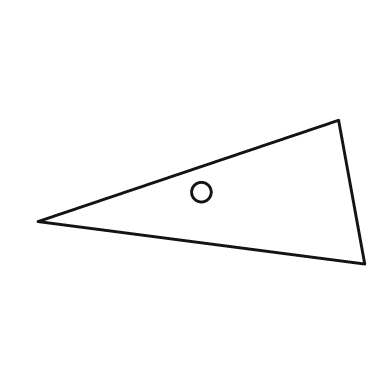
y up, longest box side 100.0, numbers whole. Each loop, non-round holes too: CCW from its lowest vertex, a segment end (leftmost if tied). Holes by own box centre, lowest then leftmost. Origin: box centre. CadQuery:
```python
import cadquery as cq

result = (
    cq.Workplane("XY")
    .moveTo(50.0, -22.0)
    .lineTo(42.0, 22.0)
    .lineTo(-50.0, -9.0)
    .close()
    .moveTo(0.0, 0.0)
    .circle(3.0)
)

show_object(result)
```